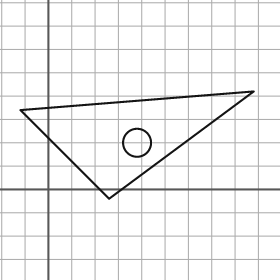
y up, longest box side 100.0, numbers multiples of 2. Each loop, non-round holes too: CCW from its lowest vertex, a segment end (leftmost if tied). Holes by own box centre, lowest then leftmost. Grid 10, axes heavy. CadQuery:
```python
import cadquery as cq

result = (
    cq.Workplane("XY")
    .moveTo(26.0, -4.0)
    .lineTo(88.0, 42.0)
    .lineTo(-12.0, 34.0)
    .close()
    .moveTo(38.0, 20.0)
    .circle(6.0)
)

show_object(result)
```